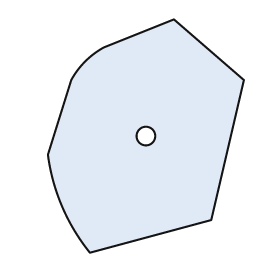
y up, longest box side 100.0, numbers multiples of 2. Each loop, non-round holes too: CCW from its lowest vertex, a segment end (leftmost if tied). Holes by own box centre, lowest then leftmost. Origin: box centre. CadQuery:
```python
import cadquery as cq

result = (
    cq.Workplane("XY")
    .moveTo(-24.0, -50.0)
    .lineTo(28.0, -36.0)
    .lineTo(42.0, 24.0)
    .lineTo(12.0, 50.0)
    .lineTo(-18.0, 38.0)
    .threePointArc((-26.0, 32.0), (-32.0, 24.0))
    .lineTo(-42.0, -8.0)
    .threePointArc((-36.0, -30.0), (-24.0, -50.0))
    .close()
    .moveTo(0.0, 0.0)
    .circle(4.0)
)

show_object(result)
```